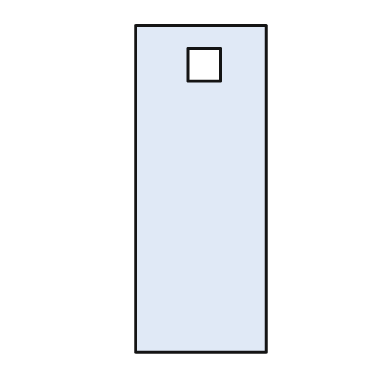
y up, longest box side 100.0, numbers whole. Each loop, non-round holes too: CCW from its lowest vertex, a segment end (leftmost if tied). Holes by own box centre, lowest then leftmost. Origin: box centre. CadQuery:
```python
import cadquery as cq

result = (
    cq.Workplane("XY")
    .moveTo(-20.0, -50.0)
    .lineTo(20.0, -50.0)
    .lineTo(20.0, 50.0)
    .lineTo(-20.0, 50.0)
    .close()
    .moveTo(-4.0, 33.0)
    .lineTo(6.0, 33.0)
    .lineTo(6.0, 43.0)
    .lineTo(-4.0, 43.0)
    .close()
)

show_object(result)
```